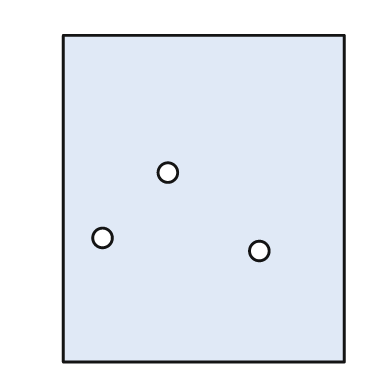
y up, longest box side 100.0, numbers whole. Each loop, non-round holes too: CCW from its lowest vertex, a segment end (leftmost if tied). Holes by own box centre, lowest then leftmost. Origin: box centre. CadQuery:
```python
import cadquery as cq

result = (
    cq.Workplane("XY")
    .moveTo(-43.0, -50.0)
    .lineTo(43.0, -50.0)
    .lineTo(43.0, 50.0)
    .lineTo(-43.0, 50.0)
    .close()
    .moveTo(17.0, -16.0)
    .circle(3.0)
    .moveTo(-31.0, -12.0)
    .circle(3.0)
    .moveTo(-11.0, 8.0)
    .circle(3.0)
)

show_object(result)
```